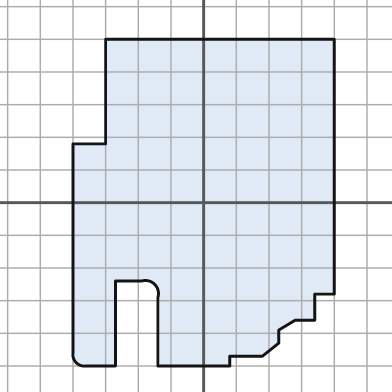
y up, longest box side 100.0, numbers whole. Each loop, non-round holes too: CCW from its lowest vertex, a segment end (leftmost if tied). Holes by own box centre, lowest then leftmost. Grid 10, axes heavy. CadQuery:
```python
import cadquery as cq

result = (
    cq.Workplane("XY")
    .moveTo(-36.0, -50.0)
    .lineTo(-27.0, -50.0)
    .lineTo(-27.0, -24.0)
    .lineTo(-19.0, -24.0)
    .threePointArc((-15.0, -25.0), (-14.0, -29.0))
    .lineTo(-14.0, -50.0)
    .lineTo(8.0, -50.0)
    .lineTo(8.0, -47.0)
    .lineTo(18.0, -47.0)
    .lineTo(23.0, -43.0)
    .lineTo(23.0, -39.0)
    .lineTo(28.0, -36.0)
    .lineTo(34.0, -36.0)
    .lineTo(34.0, -28.0)
    .lineTo(40.0, -28.0)
    .lineTo(40.0, 50.0)
    .lineTo(-30.0, 50.0)
    .lineTo(-30.0, 18.0)
    .lineTo(-40.0, 18.0)
    .lineTo(-40.0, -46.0)
    .threePointArc((-39.0, -49.0), (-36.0, -50.0))
    .close()
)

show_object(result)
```